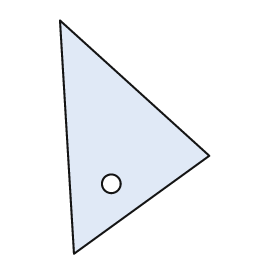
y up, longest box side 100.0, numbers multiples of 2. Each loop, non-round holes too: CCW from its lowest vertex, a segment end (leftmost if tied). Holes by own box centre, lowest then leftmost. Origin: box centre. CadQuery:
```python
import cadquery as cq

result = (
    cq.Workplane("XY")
    .moveTo(-26.0, -50.0)
    .lineTo(32.0, -8.0)
    .lineTo(-32.0, 50.0)
    .close()
    .moveTo(-10.0, -20.0)
    .circle(4.0)
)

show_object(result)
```